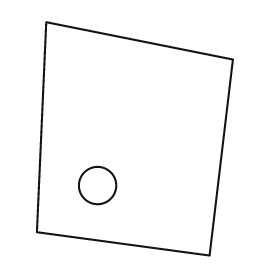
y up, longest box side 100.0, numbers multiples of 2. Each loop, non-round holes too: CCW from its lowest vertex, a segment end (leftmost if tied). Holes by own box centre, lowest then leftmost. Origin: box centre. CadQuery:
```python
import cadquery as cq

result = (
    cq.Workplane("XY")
    .moveTo(32.0, -50.0)
    .lineTo(42.0, 34.0)
    .lineTo(-38.0, 50.0)
    .lineTo(-42.0, -40.0)
    .close()
    .moveTo(-16.0, -20.0)
    .circle(8.0)
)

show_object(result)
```